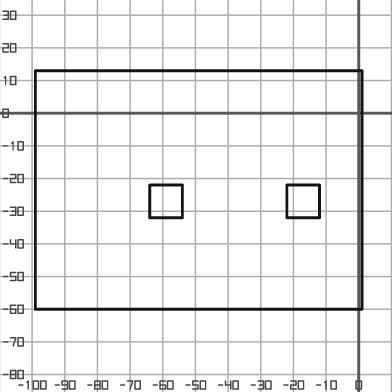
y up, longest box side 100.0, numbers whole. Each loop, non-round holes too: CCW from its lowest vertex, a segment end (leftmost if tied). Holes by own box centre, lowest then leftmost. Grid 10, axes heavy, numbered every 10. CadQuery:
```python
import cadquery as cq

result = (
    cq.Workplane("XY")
    .moveTo(-99.0, -60.0)
    .lineTo(1.0, -60.0)
    .lineTo(1.0, 13.0)
    .lineTo(-99.0, 13.0)
    .close()
    .moveTo(-64.0, -32.0)
    .lineTo(-54.0, -32.0)
    .lineTo(-54.0, -22.0)
    .lineTo(-64.0, -22.0)
    .close()
    .moveTo(-22.0, -32.0)
    .lineTo(-12.0, -32.0)
    .lineTo(-12.0, -22.0)
    .lineTo(-22.0, -22.0)
    .close()
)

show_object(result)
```